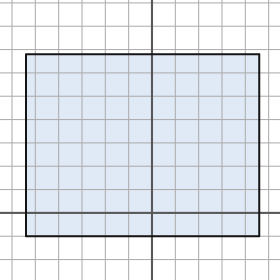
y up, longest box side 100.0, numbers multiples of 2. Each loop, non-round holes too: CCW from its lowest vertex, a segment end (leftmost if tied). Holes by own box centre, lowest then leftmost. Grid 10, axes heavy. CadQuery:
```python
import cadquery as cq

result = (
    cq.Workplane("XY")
    .moveTo(-54.0, -10.0)
    .lineTo(46.0, -10.0)
    .lineTo(46.0, 68.0)
    .lineTo(-54.0, 68.0)
    .close()
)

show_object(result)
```